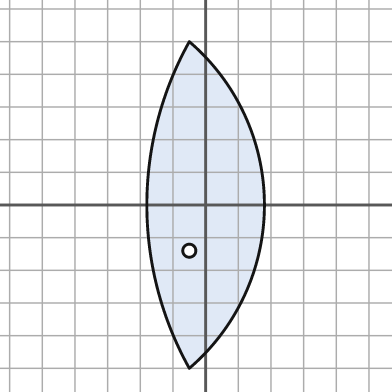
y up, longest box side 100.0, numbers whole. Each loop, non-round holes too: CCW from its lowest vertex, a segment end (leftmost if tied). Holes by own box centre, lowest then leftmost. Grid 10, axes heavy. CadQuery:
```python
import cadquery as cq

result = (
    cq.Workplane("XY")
    .moveTo(-5.0, -50.0)
    .threePointArc((18.0, 0.0), (-5.0, 50.0))
    .threePointArc((-18.0, 0.0), (-5.0, -50.0))
    .close()
    .moveTo(-5.0, -14.0)
    .circle(2.0)
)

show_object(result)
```